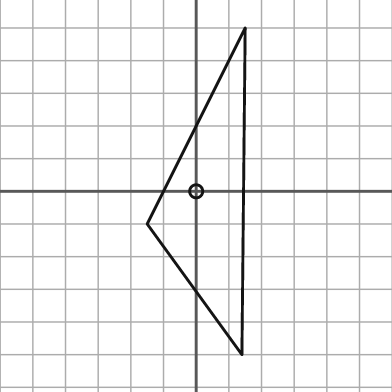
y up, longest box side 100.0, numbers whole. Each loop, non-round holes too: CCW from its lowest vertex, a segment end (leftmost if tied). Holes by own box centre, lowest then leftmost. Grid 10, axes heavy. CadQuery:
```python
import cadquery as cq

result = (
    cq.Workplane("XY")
    .moveTo(14.0, -50.0)
    .lineTo(15.0, 50.0)
    .lineTo(-15.0, -10.0)
    .close()
    .moveTo(0.0, 0.0)
    .circle(2.0)
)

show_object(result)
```